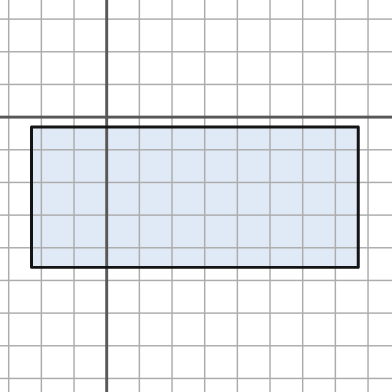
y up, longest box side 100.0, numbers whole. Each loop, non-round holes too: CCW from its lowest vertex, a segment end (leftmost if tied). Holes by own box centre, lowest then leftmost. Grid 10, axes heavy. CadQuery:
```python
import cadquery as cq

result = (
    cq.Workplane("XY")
    .moveTo(-23.0, -46.0)
    .lineTo(77.0, -46.0)
    .lineTo(77.0, -3.0)
    .lineTo(-23.0, -3.0)
    .close()
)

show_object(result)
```